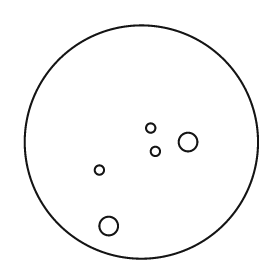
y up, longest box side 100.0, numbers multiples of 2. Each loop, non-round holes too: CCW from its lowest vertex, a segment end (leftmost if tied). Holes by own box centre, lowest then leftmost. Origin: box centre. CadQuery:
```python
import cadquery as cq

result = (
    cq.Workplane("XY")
    .moveTo(0.0, 0.0)
    .circle(50.0)
    .moveTo(-14.0, -36.0)
    .circle(4.0)
    .moveTo(-18.0, -12.0)
    .circle(2.0)
    .moveTo(6.0, -4.0)
    .circle(2.0)
    .moveTo(20.0, 0.0)
    .circle(4.0)
    .moveTo(4.0, 6.0)
    .circle(2.0)
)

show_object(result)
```